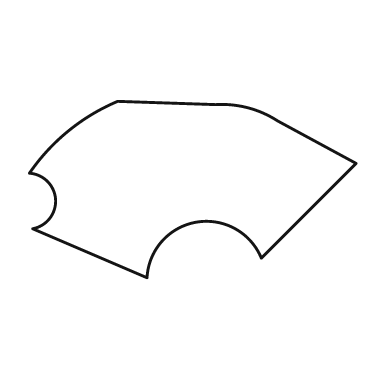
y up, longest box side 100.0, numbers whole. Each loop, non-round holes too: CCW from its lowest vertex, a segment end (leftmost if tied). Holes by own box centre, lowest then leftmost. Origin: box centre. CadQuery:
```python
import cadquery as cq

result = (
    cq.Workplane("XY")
    .moveTo(-14.0, -27.0)
    .threePointArc((1.0, -10.0), (21.0, -21.0))
    .lineTo(50.0, 8.0)
    .lineTo(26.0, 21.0)
    .threePointArc((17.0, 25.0), (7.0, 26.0))
    .lineTo(-23.0, 27.0)
    .threePointArc((-38.0, 18.0), (-50.0, 5.0))
    .threePointArc((-42.0, -3.0), (-49.0, -12.0))
    .close()
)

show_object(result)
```